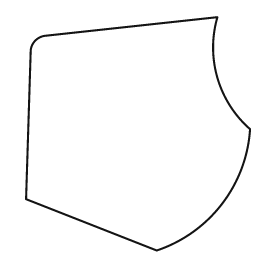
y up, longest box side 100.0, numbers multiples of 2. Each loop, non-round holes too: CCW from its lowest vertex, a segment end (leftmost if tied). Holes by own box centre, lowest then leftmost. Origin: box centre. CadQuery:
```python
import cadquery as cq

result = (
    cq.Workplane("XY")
    .moveTo(8.0, -50.0)
    .threePointArc((36.0, -30.0), (48.0, 2.0))
    .threePointArc((34.0, 24.0), (34.0, 50.0))
    .lineTo(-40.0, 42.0)
    .threePointArc((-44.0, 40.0), (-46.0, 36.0))
    .lineTo(-48.0, -28.0)
    .close()
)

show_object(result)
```